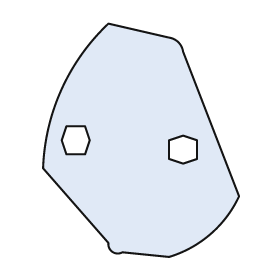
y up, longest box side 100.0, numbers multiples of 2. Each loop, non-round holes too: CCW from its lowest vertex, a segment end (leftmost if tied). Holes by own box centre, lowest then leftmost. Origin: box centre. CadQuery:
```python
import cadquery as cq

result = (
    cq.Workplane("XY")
    .moveTo(12.0, -50.0)
    .threePointArc((30.0, -40.0), (42.0, -24.0))
    .lineTo(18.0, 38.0)
    .threePointArc((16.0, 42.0), (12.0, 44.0))
    .lineTo(-14.0, 50.0)
    .threePointArc((-34.0, 22.0), (-42.0, -12.0))
    .lineTo(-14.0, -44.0)
    .threePointArc((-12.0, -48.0), (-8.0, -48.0))
    .close()
    .moveTo(18.0, -10.0)
    .lineTo(24.0, -8.0)
    .lineTo(24.0, 0.0)
    .lineTo(18.0, 2.0)
    .lineTo(12.0, 0.0)
    .lineTo(12.0, -8.0)
    .close()
    .moveTo(-32.0, -6.0)
    .lineTo(-24.0, -6.0)
    .lineTo(-22.0, 0.0)
    .lineTo(-24.0, 6.0)
    .lineTo(-32.0, 6.0)
    .lineTo(-34.0, 0.0)
    .close()
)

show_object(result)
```